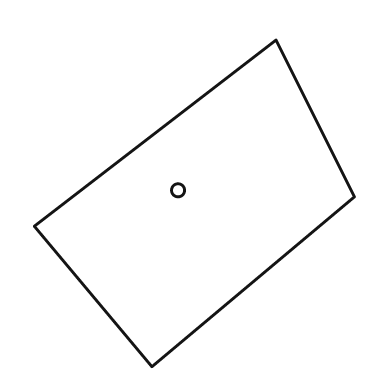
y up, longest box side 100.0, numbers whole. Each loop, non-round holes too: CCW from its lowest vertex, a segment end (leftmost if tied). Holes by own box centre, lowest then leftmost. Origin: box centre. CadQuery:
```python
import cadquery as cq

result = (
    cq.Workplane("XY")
    .moveTo(-13.0, -50.0)
    .lineTo(49.0, 2.0)
    .lineTo(25.0, 50.0)
    .lineTo(-49.0, -7.0)
    .close()
    .moveTo(-5.0, 4.0)
    .circle(2.0)
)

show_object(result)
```